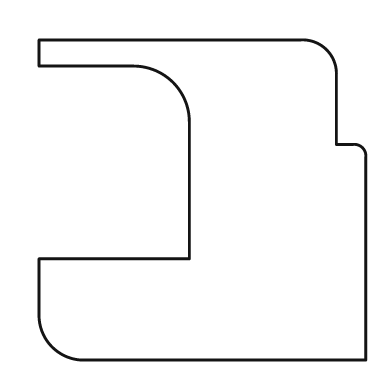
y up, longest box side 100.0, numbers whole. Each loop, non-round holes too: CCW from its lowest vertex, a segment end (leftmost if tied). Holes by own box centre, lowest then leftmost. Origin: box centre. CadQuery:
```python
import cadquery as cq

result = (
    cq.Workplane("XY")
    .moveTo(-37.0, -49.0)
    .lineTo(50.0, -49.0)
    .lineTo(50.0, 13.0)
    .threePointArc((49.0, 16.0), (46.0, 17.0))
    .lineTo(41.0, 17.0)
    .lineTo(41.0, 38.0)
    .threePointArc((38.0, 46.0), (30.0, 49.0))
    .lineTo(-50.0, 49.0)
    .lineTo(-50.0, 41.0)
    .lineTo(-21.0, 41.0)
    .threePointArc((-9.0, 36.0), (-4.0, 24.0))
    .lineTo(-4.0, -18.0)
    .lineTo(-50.0, -18.0)
    .lineTo(-50.0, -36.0)
    .threePointArc((-46.0, -45.0), (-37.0, -49.0))
    .close()
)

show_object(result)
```